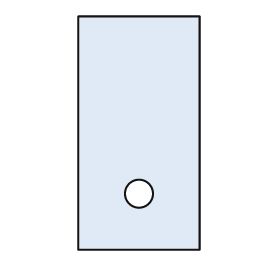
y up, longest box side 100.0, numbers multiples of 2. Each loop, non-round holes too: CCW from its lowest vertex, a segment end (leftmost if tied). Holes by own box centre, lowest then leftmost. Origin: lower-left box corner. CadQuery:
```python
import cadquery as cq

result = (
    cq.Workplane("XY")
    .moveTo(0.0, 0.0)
    .lineTo(52.0, 0.0)
    .lineTo(52.0, 100.0)
    .lineTo(0.0, 100.0)
    .close()
    .moveTo(26.0, 24.0)
    .circle(6.0)
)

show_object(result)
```